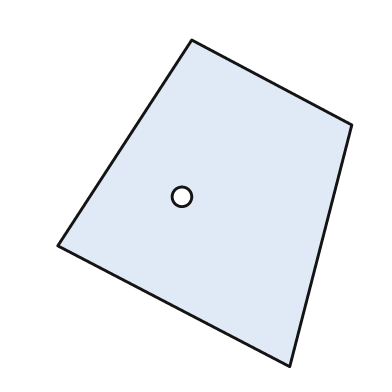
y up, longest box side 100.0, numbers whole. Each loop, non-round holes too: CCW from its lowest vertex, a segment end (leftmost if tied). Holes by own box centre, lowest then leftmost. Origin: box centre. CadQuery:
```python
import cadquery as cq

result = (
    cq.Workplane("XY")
    .moveTo(26.0, -50.0)
    .lineTo(45.0, 24.0)
    .lineTo(-4.0, 50.0)
    .lineTo(-45.0, -13.0)
    .close()
    .moveTo(-7.0, 2.0)
    .circle(3.0)
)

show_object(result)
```